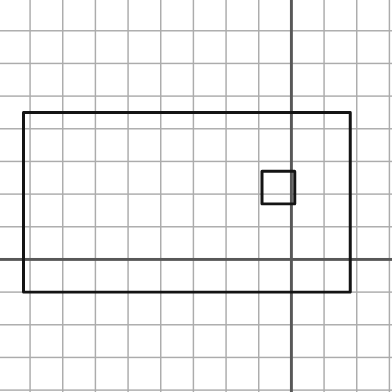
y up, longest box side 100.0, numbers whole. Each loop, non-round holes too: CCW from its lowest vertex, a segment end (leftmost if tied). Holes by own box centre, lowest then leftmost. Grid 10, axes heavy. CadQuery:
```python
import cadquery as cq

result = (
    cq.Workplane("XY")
    .moveTo(-82.0, -10.0)
    .lineTo(18.0, -10.0)
    .lineTo(18.0, 45.0)
    .lineTo(-82.0, 45.0)
    .close()
    .moveTo(-9.0, 17.0)
    .lineTo(1.0, 17.0)
    .lineTo(1.0, 27.0)
    .lineTo(-9.0, 27.0)
    .close()
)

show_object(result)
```